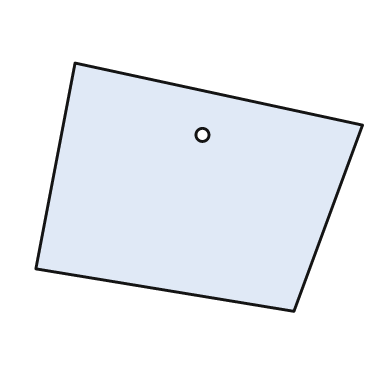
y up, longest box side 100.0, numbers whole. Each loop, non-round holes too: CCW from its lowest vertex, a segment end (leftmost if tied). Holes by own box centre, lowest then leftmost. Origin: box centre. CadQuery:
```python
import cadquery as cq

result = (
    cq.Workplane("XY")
    .moveTo(29.0, -38.0)
    .lineTo(50.0, 19.0)
    .lineTo(-38.0, 38.0)
    .lineTo(-50.0, -25.0)
    .close()
    .moveTo(1.0, 16.0)
    .circle(2.0)
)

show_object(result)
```